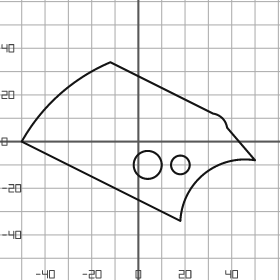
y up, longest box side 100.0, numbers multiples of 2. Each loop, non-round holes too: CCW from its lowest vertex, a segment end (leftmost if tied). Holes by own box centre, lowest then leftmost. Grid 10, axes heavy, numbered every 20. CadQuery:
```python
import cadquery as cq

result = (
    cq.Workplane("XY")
    .moveTo(18.0, -34.0)
    .threePointArc((28.0, -14.0), (50.0, -8.0))
    .lineTo(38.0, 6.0)
    .threePointArc((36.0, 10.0), (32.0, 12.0))
    .lineTo(-12.0, 34.0)
    .threePointArc((-34.0, 20.0), (-50.0, 0.0))
    .close()
    .moveTo(4.0, -10.0)
    .circle(6.0)
    .moveTo(18.0, -10.0)
    .circle(4.0)
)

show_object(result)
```